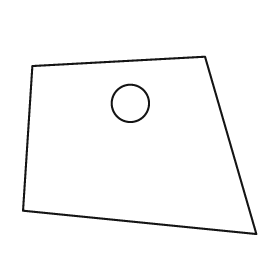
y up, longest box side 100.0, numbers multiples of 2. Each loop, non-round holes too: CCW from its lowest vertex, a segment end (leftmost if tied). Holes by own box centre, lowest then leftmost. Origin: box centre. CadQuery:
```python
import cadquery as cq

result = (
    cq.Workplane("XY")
    .moveTo(50.0, -38.0)
    .lineTo(28.0, 38.0)
    .lineTo(-46.0, 34.0)
    .lineTo(-50.0, -28.0)
    .close()
    .moveTo(-4.0, 18.0)
    .circle(8.0)
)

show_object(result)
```